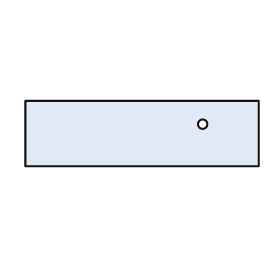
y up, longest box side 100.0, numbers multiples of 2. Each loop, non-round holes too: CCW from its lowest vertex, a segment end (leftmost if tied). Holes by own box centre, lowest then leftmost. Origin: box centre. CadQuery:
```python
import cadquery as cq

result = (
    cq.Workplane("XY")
    .moveTo(-50.0, -14.0)
    .lineTo(50.0, -14.0)
    .lineTo(50.0, 14.0)
    .lineTo(-50.0, 14.0)
    .close()
    .moveTo(26.0, 4.0)
    .circle(2.0)
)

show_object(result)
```